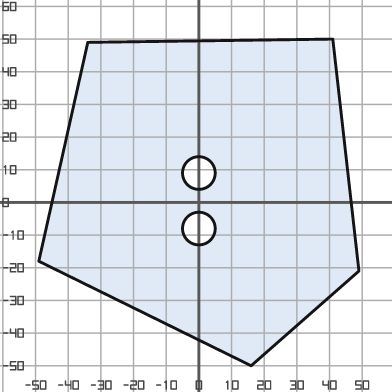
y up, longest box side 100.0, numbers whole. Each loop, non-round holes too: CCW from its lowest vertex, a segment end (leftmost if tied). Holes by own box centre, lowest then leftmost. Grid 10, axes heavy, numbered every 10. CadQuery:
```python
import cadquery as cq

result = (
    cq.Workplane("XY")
    .moveTo(16.0, -50.0)
    .lineTo(49.0, -21.0)
    .lineTo(41.0, 50.0)
    .lineTo(-34.0, 49.0)
    .lineTo(-49.0, -18.0)
    .close()
    .moveTo(0.0, -8.0)
    .circle(5.0)
    .moveTo(0.0, 9.0)
    .circle(5.0)
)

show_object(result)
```